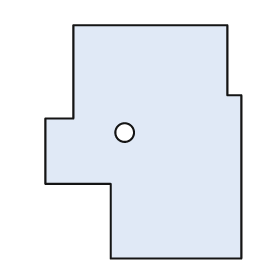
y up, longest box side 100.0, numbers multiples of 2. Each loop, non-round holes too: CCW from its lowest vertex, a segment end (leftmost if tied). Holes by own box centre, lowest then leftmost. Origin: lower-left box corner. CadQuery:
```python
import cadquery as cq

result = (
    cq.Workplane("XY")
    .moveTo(28.0, 0.0)
    .lineTo(84.0, 0.0)
    .lineTo(84.0, 70.0)
    .lineTo(78.0, 70.0)
    .lineTo(78.0, 100.0)
    .lineTo(12.0, 100.0)
    .lineTo(12.0, 60.0)
    .lineTo(0.0, 60.0)
    .lineTo(0.0, 32.0)
    .lineTo(28.0, 32.0)
    .close()
    .moveTo(34.0, 54.0)
    .circle(4.0)
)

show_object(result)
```